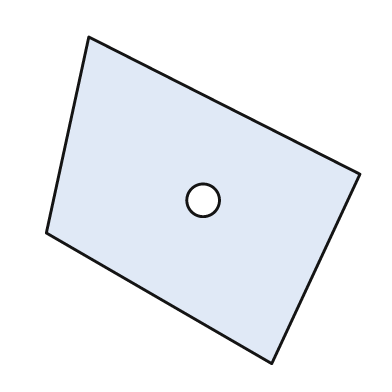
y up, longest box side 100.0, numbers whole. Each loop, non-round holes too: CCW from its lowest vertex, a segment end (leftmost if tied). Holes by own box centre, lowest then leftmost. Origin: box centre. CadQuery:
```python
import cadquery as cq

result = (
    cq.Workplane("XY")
    .moveTo(21.0, -50.0)
    .lineTo(48.0, 8.0)
    .lineTo(-35.0, 50.0)
    .lineTo(-48.0, -10.0)
    .close()
    .moveTo(0.0, 0.0)
    .circle(5.0)
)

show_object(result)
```